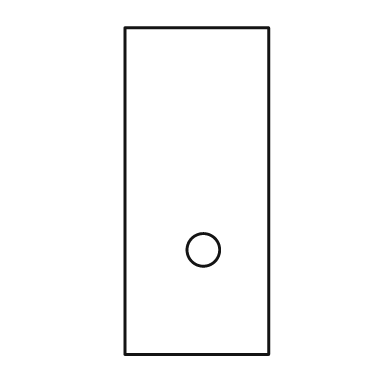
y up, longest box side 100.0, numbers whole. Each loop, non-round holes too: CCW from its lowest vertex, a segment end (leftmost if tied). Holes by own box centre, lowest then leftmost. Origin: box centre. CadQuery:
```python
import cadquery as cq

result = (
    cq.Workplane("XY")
    .moveTo(-22.0, -50.0)
    .lineTo(22.0, -50.0)
    .lineTo(22.0, 50.0)
    .lineTo(-22.0, 50.0)
    .close()
    .moveTo(2.0, -18.0)
    .circle(5.0)
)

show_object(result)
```